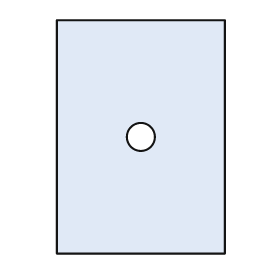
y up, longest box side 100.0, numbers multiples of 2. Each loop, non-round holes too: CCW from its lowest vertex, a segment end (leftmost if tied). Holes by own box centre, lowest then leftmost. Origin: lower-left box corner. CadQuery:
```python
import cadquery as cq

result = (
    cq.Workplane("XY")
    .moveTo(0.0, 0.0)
    .lineTo(72.0, 0.0)
    .lineTo(72.0, 100.0)
    .lineTo(0.0, 100.0)
    .close()
    .moveTo(36.0, 50.0)
    .circle(6.0)
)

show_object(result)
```